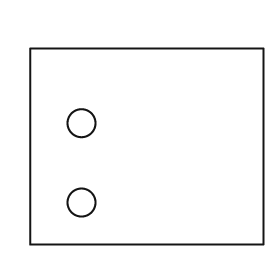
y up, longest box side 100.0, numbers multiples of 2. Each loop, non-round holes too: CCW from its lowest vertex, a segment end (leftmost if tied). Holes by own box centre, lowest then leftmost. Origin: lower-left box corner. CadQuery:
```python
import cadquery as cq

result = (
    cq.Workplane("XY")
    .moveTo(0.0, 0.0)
    .lineTo(100.0, 0.0)
    .lineTo(100.0, 84.0)
    .lineTo(0.0, 84.0)
    .close()
    .moveTo(22.0, 18.0)
    .circle(6.0)
    .moveTo(22.0, 52.0)
    .circle(6.0)
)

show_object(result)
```